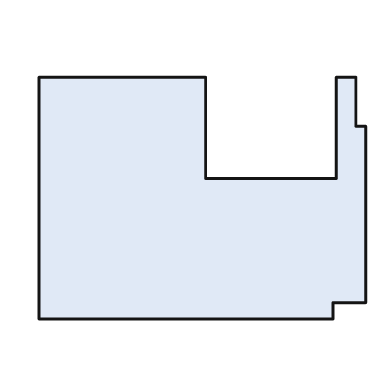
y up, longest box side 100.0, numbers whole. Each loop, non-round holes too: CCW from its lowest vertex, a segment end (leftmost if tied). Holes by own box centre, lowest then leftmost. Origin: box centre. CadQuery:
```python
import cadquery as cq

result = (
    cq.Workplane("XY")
    .moveTo(-50.0, -37.0)
    .lineTo(40.0, -37.0)
    .lineTo(40.0, -32.0)
    .lineTo(50.0, -32.0)
    .lineTo(50.0, 22.0)
    .lineTo(47.0, 22.0)
    .lineTo(47.0, 37.0)
    .lineTo(41.0, 37.0)
    .lineTo(41.0, 6.0)
    .lineTo(1.0, 6.0)
    .lineTo(1.0, 37.0)
    .lineTo(-50.0, 37.0)
    .close()
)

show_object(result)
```